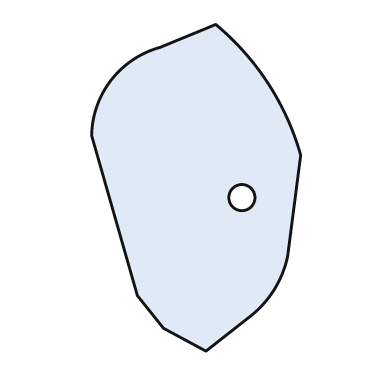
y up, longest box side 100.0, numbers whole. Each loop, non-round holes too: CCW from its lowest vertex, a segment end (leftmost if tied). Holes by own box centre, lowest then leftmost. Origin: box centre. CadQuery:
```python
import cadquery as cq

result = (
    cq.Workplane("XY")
    .moveTo(3.0, -50.0)
    .lineTo(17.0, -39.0)
    .threePointArc((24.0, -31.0), (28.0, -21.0))
    .lineTo(32.0, 10.0)
    .threePointArc((22.0, 32.0), (6.0, 50.0))
    .lineTo(-11.0, 43.0)
    .threePointArc((-26.0, 33.0), (-32.0, 16.0))
    .lineTo(-18.0, -33.0)
    .lineTo(-10.0, -43.0)
    .close()
    .moveTo(14.0, -3.0)
    .circle(4.0)
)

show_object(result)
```